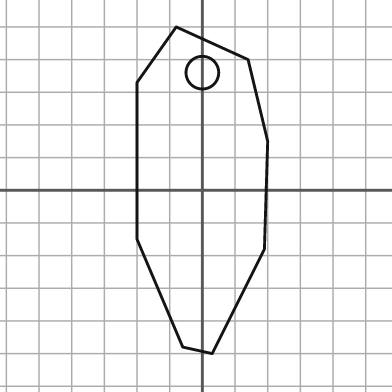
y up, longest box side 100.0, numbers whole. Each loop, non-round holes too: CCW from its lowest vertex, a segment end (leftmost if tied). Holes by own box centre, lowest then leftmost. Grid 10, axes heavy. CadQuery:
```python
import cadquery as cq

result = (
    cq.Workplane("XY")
    .moveTo(3.0, -50.0)
    .lineTo(19.0, -18.0)
    .lineTo(20.0, 15.0)
    .lineTo(14.0, 40.0)
    .lineTo(-8.0, 50.0)
    .lineTo(-20.0, 33.0)
    .lineTo(-20.0, -15.0)
    .lineTo(-6.0, -48.0)
    .close()
    .moveTo(0.0, 36.0)
    .circle(5.0)
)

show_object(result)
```